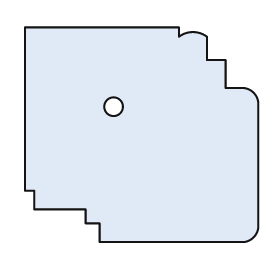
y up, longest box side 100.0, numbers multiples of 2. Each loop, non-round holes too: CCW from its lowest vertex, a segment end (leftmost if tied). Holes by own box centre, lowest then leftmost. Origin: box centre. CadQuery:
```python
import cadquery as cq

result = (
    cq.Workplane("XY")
    .moveTo(-18.0, -46.0)
    .lineTo(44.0, -46.0)
    .threePointArc((48.0, -44.0), (50.0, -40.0))
    .lineTo(50.0, 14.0)
    .threePointArc((48.0, 18.0), (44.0, 20.0))
    .lineTo(36.0, 20.0)
    .lineTo(36.0, 32.0)
    .lineTo(28.0, 32.0)
    .lineTo(28.0, 42.0)
    .threePointArc((22.0, 44.0), (16.0, 42.0))
    .lineTo(16.0, 46.0)
    .lineTo(-50.0, 46.0)
    .lineTo(-50.0, -24.0)
    .lineTo(-46.0, -24.0)
    .lineTo(-46.0, -32.0)
    .lineTo(-24.0, -32.0)
    .lineTo(-24.0, -38.0)
    .lineTo(-18.0, -38.0)
    .close()
    .moveTo(-12.0, 12.0)
    .circle(4.0)
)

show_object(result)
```